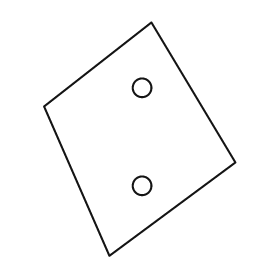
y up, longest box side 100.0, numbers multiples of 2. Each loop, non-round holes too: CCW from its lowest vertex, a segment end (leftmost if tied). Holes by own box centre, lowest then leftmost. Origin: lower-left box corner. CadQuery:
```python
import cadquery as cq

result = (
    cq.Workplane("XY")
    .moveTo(28.0, 0.0)
    .lineTo(82.0, 40.0)
    .lineTo(46.0, 100.0)
    .lineTo(0.0, 64.0)
    .close()
    .moveTo(42.0, 30.0)
    .circle(4.0)
    .moveTo(42.0, 72.0)
    .circle(4.0)
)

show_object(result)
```